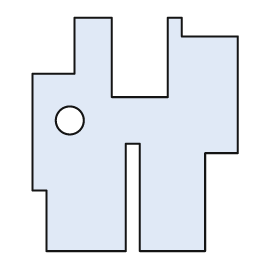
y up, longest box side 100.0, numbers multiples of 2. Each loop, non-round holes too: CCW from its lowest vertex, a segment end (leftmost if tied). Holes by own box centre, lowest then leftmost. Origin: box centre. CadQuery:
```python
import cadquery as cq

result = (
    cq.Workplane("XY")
    .moveTo(-38.0, -50.0)
    .lineTo(-4.0, -50.0)
    .lineTo(-4.0, -4.0)
    .lineTo(2.0, -4.0)
    .lineTo(2.0, -50.0)
    .lineTo(30.0, -50.0)
    .lineTo(30.0, -8.0)
    .lineTo(44.0, -8.0)
    .lineTo(44.0, 42.0)
    .lineTo(20.0, 42.0)
    .lineTo(20.0, 50.0)
    .lineTo(14.0, 50.0)
    .lineTo(14.0, 16.0)
    .lineTo(-10.0, 16.0)
    .lineTo(-10.0, 50.0)
    .lineTo(-26.0, 50.0)
    .lineTo(-26.0, 26.0)
    .lineTo(-44.0, 26.0)
    .lineTo(-44.0, -24.0)
    .lineTo(-38.0, -24.0)
    .close()
    .moveTo(-28.0, 6.0)
    .circle(6.0)
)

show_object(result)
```